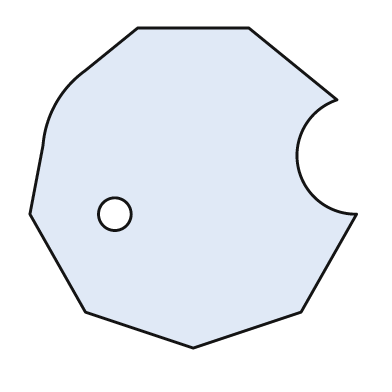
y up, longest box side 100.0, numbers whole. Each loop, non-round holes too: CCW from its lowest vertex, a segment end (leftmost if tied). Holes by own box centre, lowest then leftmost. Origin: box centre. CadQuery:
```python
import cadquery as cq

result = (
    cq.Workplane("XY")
    .moveTo(0.0, -49.0)
    .lineTo(33.0, -38.0)
    .lineTo(50.0, -8.0)
    .threePointArc((32.0, 7.0), (44.0, 27.0))
    .lineTo(17.0, 49.0)
    .lineTo(-17.0, 49.0)
    .lineTo(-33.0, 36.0)
    .threePointArc((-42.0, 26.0), (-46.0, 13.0))
    .lineTo(-50.0, -8.0)
    .lineTo(-33.0, -38.0)
    .close()
    .moveTo(-24.0, -8.0)
    .circle(5.0)
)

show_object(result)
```